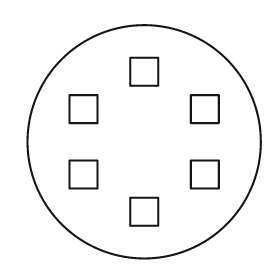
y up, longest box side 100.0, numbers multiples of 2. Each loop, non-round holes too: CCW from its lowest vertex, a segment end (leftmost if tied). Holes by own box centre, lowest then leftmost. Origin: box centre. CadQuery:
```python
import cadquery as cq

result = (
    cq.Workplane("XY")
    .moveTo(0.0, 0.0)
    .circle(50.0)
    .moveTo(-6.0, -36.0)
    .lineTo(6.0, -36.0)
    .lineTo(6.0, -24.0)
    .lineTo(-6.0, -24.0)
    .close()
    .moveTo(-32.0, -20.0)
    .lineTo(-20.0, -20.0)
    .lineTo(-20.0, -8.0)
    .lineTo(-32.0, -8.0)
    .close()
    .moveTo(20.0, -20.0)
    .lineTo(32.0, -20.0)
    .lineTo(32.0, -8.0)
    .lineTo(20.0, -8.0)
    .close()
    .moveTo(-32.0, 8.0)
    .lineTo(-20.0, 8.0)
    .lineTo(-20.0, 20.0)
    .lineTo(-32.0, 20.0)
    .close()
    .moveTo(20.0, 8.0)
    .lineTo(32.0, 8.0)
    .lineTo(32.0, 20.0)
    .lineTo(20.0, 20.0)
    .close()
    .moveTo(-6.0, 24.0)
    .lineTo(6.0, 24.0)
    .lineTo(6.0, 36.0)
    .lineTo(-6.0, 36.0)
    .close()
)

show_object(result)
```